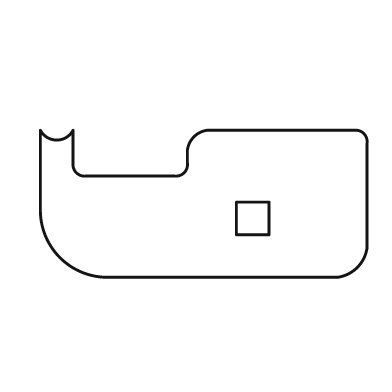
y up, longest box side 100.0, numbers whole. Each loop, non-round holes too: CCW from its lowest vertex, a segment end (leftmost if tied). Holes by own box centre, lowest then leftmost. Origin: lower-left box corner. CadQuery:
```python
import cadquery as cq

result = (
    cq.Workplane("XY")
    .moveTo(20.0, 0.0)
    .lineTo(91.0, 0.0)
    .threePointArc((97.0, 3.0), (100.0, 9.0))
    .lineTo(100.0, 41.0)
    .threePointArc((99.0, 44.0), (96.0, 45.0))
    .lineTo(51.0, 45.0)
    .threePointArc((47.0, 43.0), (45.0, 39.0))
    .lineTo(45.0, 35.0)
    .threePointArc((44.0, 32.0), (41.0, 31.0))
    .lineTo(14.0, 31.0)
    .threePointArc((11.0, 32.0), (10.0, 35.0))
    .lineTo(10.0, 45.0)
    .threePointArc((5.0, 42.0), (0.0, 45.0))
    .lineTo(0.0, 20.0)
    .threePointArc((6.0, 6.0), (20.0, 0.0))
    .close()
    .moveTo(60.0, 13.0)
    .lineTo(70.0, 13.0)
    .lineTo(70.0, 23.0)
    .lineTo(60.0, 23.0)
    .close()
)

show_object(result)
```